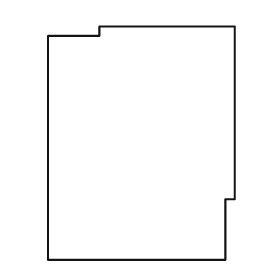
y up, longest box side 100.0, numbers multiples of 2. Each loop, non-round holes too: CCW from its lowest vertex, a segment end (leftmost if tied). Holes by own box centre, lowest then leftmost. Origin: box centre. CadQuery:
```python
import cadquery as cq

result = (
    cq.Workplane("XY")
    .moveTo(-40.0, -50.0)
    .lineTo(36.0, -50.0)
    .lineTo(36.0, -24.0)
    .lineTo(40.0, -24.0)
    .lineTo(40.0, 50.0)
    .lineTo(-18.0, 50.0)
    .lineTo(-18.0, 46.0)
    .lineTo(-40.0, 46.0)
    .close()
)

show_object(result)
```